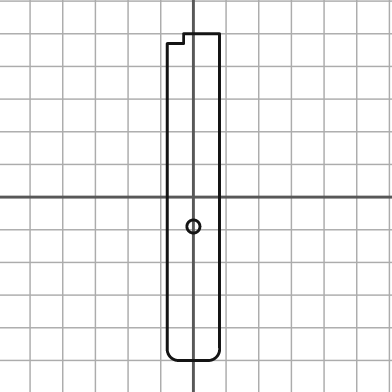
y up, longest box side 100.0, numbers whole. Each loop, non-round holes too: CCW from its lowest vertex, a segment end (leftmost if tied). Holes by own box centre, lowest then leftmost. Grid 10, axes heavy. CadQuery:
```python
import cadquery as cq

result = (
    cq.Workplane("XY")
    .moveTo(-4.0, -50.0)
    .lineTo(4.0, -50.0)
    .threePointArc((7.0, -49.0), (8.0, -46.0))
    .lineTo(8.0, 50.0)
    .lineTo(-3.0, 50.0)
    .lineTo(-3.0, 47.0)
    .lineTo(-8.0, 47.0)
    .lineTo(-8.0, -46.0)
    .threePointArc((-7.0, -49.0), (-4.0, -50.0))
    .close()
    .moveTo(0.0, -9.0)
    .circle(2.0)
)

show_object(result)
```